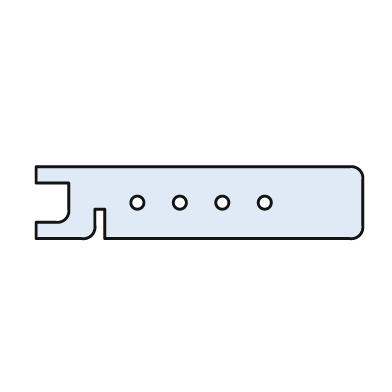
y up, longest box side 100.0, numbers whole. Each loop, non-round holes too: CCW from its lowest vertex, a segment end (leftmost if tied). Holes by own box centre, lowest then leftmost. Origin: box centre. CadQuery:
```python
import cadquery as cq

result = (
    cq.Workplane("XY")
    .moveTo(-50.0, -11.0)
    .lineTo(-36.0, -11.0)
    .threePointArc((-33.0, -10.0), (-32.0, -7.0))
    .lineTo(-32.0, -2.0)
    .lineTo(-29.0, -2.0)
    .lineTo(-29.0, -11.0)
    .lineTo(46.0, -11.0)
    .threePointArc((49.0, -10.0), (50.0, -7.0))
    .lineTo(50.0, 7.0)
    .threePointArc((49.0, 10.0), (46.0, 11.0))
    .lineTo(-50.0, 11.0)
    .lineTo(-50.0, 6.0)
    .lineTo(-40.0, 6.0)
    .lineTo(-40.0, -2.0)
    .threePointArc((-41.0, -5.0), (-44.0, -6.0))
    .lineTo(-50.0, -6.0)
    .close()
    .moveTo(-19.0, 0.0)
    .circle(2.0)
    .moveTo(-6.0, 0.0)
    .circle(2.0)
    .moveTo(7.0, 0.0)
    .circle(2.0)
    .moveTo(20.0, 0.0)
    .circle(2.0)
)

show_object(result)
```